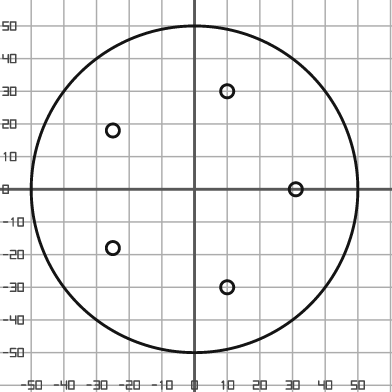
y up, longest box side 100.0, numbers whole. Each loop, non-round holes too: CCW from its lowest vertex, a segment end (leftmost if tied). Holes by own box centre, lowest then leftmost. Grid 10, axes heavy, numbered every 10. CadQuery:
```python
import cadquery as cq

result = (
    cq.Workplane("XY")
    .moveTo(0.0, 0.0)
    .circle(50.0)
    .moveTo(10.0, -30.0)
    .circle(2.0)
    .moveTo(-25.0, -18.0)
    .circle(2.0)
    .moveTo(31.0, 0.0)
    .circle(2.0)
    .moveTo(-25.0, 18.0)
    .circle(2.0)
    .moveTo(10.0, 30.0)
    .circle(2.0)
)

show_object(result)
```